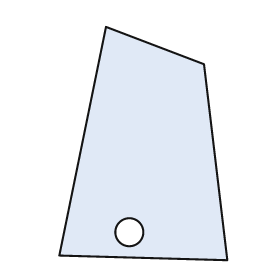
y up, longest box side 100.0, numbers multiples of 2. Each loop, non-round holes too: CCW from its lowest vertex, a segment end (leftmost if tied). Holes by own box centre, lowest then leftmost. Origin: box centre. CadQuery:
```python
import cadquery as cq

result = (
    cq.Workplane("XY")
    .moveTo(36.0, -50.0)
    .lineTo(26.0, 34.0)
    .lineTo(-16.0, 50.0)
    .lineTo(-36.0, -48.0)
    .close()
    .moveTo(-6.0, -38.0)
    .circle(6.0)
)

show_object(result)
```